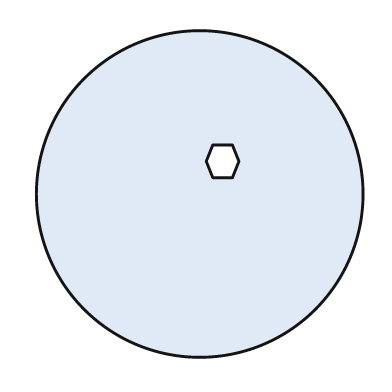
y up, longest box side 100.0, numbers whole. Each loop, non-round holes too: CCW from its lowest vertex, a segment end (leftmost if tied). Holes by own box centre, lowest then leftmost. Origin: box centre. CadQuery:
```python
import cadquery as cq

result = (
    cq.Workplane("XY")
    .moveTo(0.0, 0.0)
    .circle(50.0)
    .moveTo(4.0, 5.0)
    .lineTo(10.0, 5.0)
    .lineTo(12.0, 10.0)
    .lineTo(10.0, 15.0)
    .lineTo(4.0, 15.0)
    .lineTo(2.0, 10.0)
    .close()
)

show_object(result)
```